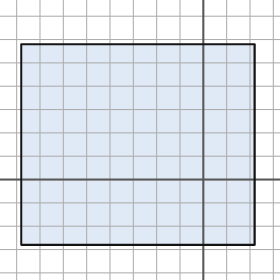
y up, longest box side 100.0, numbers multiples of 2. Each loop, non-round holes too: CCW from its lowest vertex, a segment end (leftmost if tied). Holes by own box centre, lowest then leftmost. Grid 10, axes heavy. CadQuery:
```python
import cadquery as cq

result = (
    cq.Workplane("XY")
    .moveTo(-78.0, -28.0)
    .lineTo(22.0, -28.0)
    .lineTo(22.0, 58.0)
    .lineTo(-78.0, 58.0)
    .close()
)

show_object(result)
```